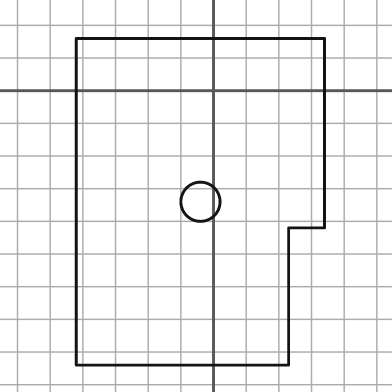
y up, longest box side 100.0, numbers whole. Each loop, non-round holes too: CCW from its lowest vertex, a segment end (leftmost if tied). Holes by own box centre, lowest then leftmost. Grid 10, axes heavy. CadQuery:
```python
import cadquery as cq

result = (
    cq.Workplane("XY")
    .moveTo(-42.0, -84.0)
    .lineTo(23.0, -84.0)
    .lineTo(23.0, -42.0)
    .lineTo(34.0, -42.0)
    .lineTo(34.0, 16.0)
    .lineTo(-42.0, 16.0)
    .close()
    .moveTo(-4.0, -34.0)
    .circle(6.0)
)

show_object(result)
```